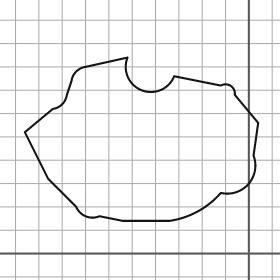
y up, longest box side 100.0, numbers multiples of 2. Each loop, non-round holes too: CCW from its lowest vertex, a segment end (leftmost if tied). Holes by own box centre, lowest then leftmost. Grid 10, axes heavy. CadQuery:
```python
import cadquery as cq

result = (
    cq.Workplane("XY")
    .moveTo(-54.0, 14.0)
    .lineTo(-34.0, 14.0)
    .threePointArc((-22.0, 18.0), (-12.0, 26.0))
    .threePointArc((0.0, 30.0), (2.0, 42.0))
    .lineTo(4.0, 56.0)
    .lineTo(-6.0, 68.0)
    .threePointArc((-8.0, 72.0), (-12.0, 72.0))
    .lineTo(-32.0, 76.0)
    .threePointArc((-46.0, 70.0), (-52.0, 84.0))
    .lineTo(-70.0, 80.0)
    .threePointArc((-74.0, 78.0), (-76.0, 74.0))
    .lineTo(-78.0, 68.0)
    .threePointArc((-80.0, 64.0), (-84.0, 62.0))
    .lineTo(-96.0, 52.0)
    .lineTo(-86.0, 32.0)
    .lineTo(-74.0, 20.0)
    .threePointArc((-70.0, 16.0), (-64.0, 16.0))
    .close()
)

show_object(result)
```